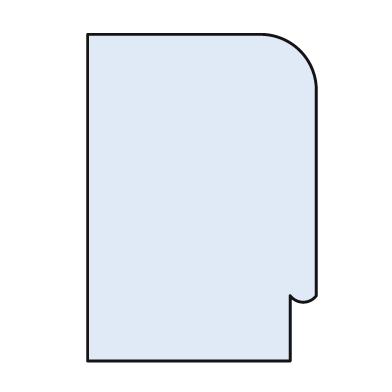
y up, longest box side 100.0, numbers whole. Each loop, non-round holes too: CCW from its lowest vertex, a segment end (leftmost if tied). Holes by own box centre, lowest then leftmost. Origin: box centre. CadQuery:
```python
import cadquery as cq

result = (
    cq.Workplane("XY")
    .moveTo(-35.0, -50.0)
    .lineTo(27.0, -50.0)
    .lineTo(27.0, -30.0)
    .threePointArc((31.0, -32.0), (35.0, -30.0))
    .lineTo(35.0, 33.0)
    .threePointArc((30.0, 45.0), (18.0, 50.0))
    .lineTo(-35.0, 50.0)
    .close()
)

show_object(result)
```